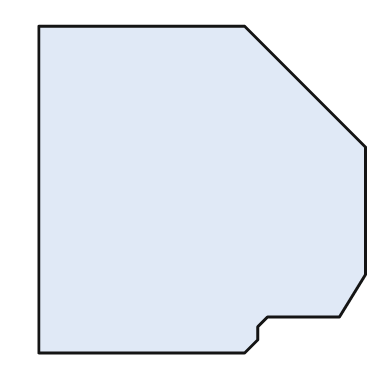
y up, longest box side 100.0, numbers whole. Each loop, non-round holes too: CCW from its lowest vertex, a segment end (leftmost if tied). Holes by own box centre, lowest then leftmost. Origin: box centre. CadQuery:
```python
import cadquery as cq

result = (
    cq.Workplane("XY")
    .moveTo(-50.0, -50.0)
    .lineTo(13.0, -50.0)
    .lineTo(17.0, -46.0)
    .lineTo(17.0, -42.0)
    .lineTo(20.0, -39.0)
    .lineTo(42.0, -39.0)
    .lineTo(50.0, -26.0)
    .lineTo(50.0, 13.0)
    .lineTo(13.0, 50.0)
    .lineTo(-50.0, 50.0)
    .close()
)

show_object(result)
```